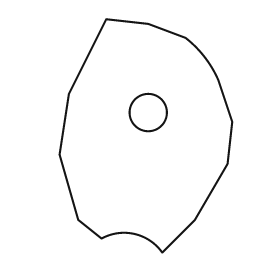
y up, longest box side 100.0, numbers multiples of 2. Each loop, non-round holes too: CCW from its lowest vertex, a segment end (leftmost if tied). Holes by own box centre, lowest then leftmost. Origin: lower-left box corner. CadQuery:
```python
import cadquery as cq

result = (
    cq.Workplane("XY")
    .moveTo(44.0, 0.0)
    .lineTo(58.0, 14.0)
    .lineTo(72.0, 38.0)
    .lineTo(74.0, 56.0)
    .lineTo(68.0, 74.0)
    .threePointArc((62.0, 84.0), (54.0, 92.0))
    .lineTo(38.0, 98.0)
    .lineTo(20.0, 100.0)
    .lineTo(4.0, 68.0)
    .lineTo(0.0, 42.0)
    .lineTo(8.0, 14.0)
    .lineTo(18.0, 6.0)
    .threePointArc((32.0, 8.0), (44.0, 0.0))
    .close()
    .moveTo(38.0, 60.0)
    .circle(8.0)
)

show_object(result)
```